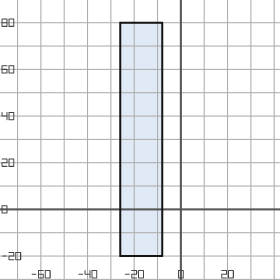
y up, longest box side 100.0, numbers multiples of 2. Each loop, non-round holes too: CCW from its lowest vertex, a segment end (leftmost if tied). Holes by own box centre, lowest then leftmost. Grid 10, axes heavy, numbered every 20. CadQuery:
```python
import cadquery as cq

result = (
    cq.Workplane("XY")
    .moveTo(-26.0, -20.0)
    .lineTo(-8.0, -20.0)
    .lineTo(-8.0, 80.0)
    .lineTo(-26.0, 80.0)
    .close()
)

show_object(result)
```